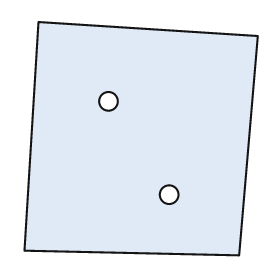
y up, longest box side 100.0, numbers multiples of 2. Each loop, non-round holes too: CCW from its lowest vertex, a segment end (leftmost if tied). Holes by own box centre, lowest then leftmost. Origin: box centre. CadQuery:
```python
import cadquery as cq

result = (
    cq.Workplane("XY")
    .moveTo(42.0, -50.0)
    .lineTo(50.0, 44.0)
    .lineTo(-44.0, 50.0)
    .lineTo(-50.0, -48.0)
    .close()
    .moveTo(12.0, -24.0)
    .circle(4.0)
    .moveTo(-14.0, 16.0)
    .circle(4.0)
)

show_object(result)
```